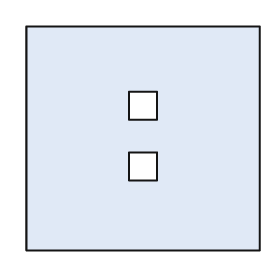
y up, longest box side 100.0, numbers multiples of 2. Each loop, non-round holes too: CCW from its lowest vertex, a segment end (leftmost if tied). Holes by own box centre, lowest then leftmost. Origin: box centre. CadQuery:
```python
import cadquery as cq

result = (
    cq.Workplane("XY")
    .moveTo(-50.0, -48.0)
    .lineTo(50.0, -48.0)
    .lineTo(50.0, 48.0)
    .lineTo(-50.0, 48.0)
    .close()
    .moveTo(-6.0, -18.0)
    .lineTo(6.0, -18.0)
    .lineTo(6.0, -6.0)
    .lineTo(-6.0, -6.0)
    .close()
    .moveTo(-6.0, 8.0)
    .lineTo(6.0, 8.0)
    .lineTo(6.0, 20.0)
    .lineTo(-6.0, 20.0)
    .close()
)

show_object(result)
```